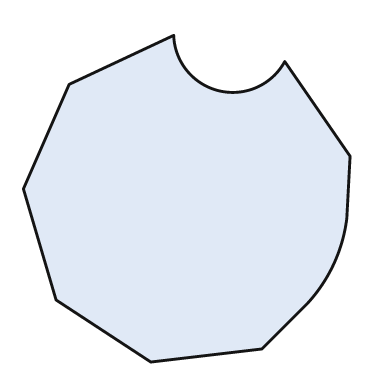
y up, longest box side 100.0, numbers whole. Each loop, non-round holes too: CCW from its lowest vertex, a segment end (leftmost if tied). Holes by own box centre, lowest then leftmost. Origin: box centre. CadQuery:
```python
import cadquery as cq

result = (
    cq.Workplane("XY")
    .moveTo(-11.0, -50.0)
    .lineTo(23.0, -46.0)
    .lineTo(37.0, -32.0)
    .threePointArc((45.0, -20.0), (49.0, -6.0))
    .lineTo(50.0, 13.0)
    .lineTo(30.0, 42.0)
    .threePointArc((10.0, 33.0), (-4.0, 50.0))
    .lineTo(-36.0, 35.0)
    .lineTo(-50.0, 3.0)
    .lineTo(-40.0, -31.0)
    .close()
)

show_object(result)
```